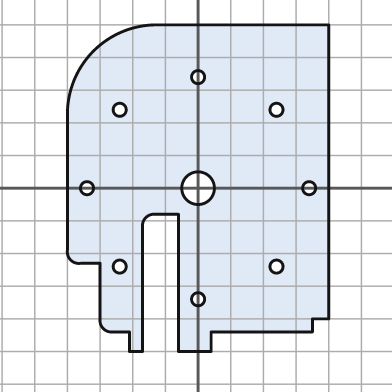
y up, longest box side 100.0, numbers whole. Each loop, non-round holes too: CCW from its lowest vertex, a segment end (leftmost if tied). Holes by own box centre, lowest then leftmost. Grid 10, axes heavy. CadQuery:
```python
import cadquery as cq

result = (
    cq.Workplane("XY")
    .moveTo(-21.0, -50.0)
    .lineTo(-17.0, -50.0)
    .lineTo(-17.0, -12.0)
    .threePointArc((-16.0, -9.0), (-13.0, -8.0))
    .lineTo(-6.0, -8.0)
    .lineTo(-6.0, -50.0)
    .lineTo(4.0, -50.0)
    .lineTo(4.0, -44.0)
    .lineTo(35.0, -44.0)
    .lineTo(35.0, -40.0)
    .lineTo(40.0, -40.0)
    .lineTo(40.0, 50.0)
    .lineTo(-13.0, 50.0)
    .threePointArc((-32.0, 42.0), (-40.0, 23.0))
    .lineTo(-40.0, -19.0)
    .threePointArc((-39.0, -22.0), (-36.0, -23.0))
    .lineTo(-30.0, -23.0)
    .lineTo(-30.0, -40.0)
    .threePointArc((-29.0, -43.0), (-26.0, -44.0))
    .lineTo(-21.0, -44.0)
    .close()
    .moveTo(0.0, -34.0)
    .circle(2.0)
    .moveTo(-24.0, -24.0)
    .circle(2.0)
    .moveTo(24.0, -24.0)
    .circle(2.0)
    .moveTo(-34.0, 0.0)
    .circle(2.0)
    .moveTo(0.0, 0.0)
    .circle(5.0)
    .moveTo(34.0, 0.0)
    .circle(2.0)
    .moveTo(-24.0, 24.0)
    .circle(2.0)
    .moveTo(24.0, 24.0)
    .circle(2.0)
    .moveTo(0.0, 34.0)
    .circle(2.0)
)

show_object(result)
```